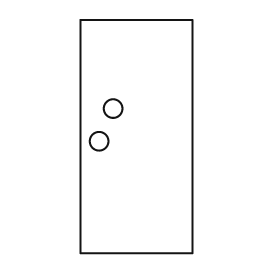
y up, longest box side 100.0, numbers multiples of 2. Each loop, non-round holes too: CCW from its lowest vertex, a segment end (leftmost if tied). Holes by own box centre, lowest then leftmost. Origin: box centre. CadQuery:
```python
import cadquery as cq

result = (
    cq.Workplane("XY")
    .moveTo(-24.0, -50.0)
    .lineTo(24.0, -50.0)
    .lineTo(24.0, 50.0)
    .lineTo(-24.0, 50.0)
    .close()
    .moveTo(-16.0, -2.0)
    .circle(4.0)
    .moveTo(-10.0, 12.0)
    .circle(4.0)
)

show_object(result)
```